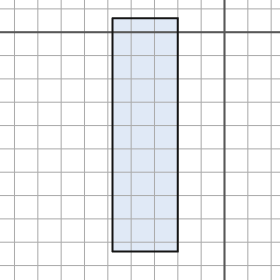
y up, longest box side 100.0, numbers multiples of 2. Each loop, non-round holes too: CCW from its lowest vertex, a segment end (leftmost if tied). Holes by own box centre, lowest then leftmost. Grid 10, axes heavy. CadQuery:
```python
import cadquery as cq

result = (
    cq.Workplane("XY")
    .moveTo(-48.0, -94.0)
    .lineTo(-20.0, -94.0)
    .lineTo(-20.0, 6.0)
    .lineTo(-48.0, 6.0)
    .close()
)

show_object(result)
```